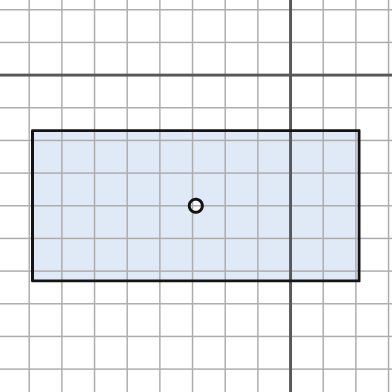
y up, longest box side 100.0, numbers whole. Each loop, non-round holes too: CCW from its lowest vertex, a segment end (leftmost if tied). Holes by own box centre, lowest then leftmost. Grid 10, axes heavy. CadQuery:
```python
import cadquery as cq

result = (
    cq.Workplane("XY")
    .moveTo(-79.0, -63.0)
    .lineTo(21.0, -63.0)
    .lineTo(21.0, -17.0)
    .lineTo(-79.0, -17.0)
    .close()
    .moveTo(-29.0, -40.0)
    .circle(2.0)
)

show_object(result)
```